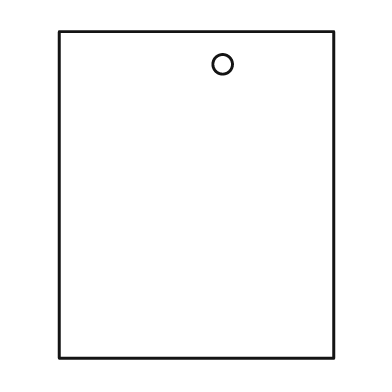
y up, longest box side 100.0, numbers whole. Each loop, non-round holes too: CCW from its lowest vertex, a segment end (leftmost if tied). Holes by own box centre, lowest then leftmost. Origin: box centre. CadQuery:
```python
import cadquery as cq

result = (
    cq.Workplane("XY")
    .moveTo(-42.0, -50.0)
    .lineTo(42.0, -50.0)
    .lineTo(42.0, 50.0)
    .lineTo(-42.0, 50.0)
    .close()
    .moveTo(8.0, 40.0)
    .circle(3.0)
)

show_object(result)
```